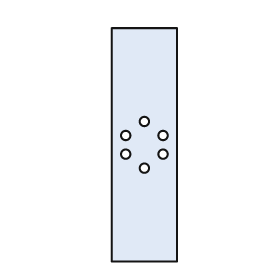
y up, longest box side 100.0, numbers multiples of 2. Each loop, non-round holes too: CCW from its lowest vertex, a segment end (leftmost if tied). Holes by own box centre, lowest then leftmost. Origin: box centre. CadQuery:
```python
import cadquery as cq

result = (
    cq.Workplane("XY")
    .moveTo(-14.0, -50.0)
    .lineTo(14.0, -50.0)
    .lineTo(14.0, 50.0)
    .lineTo(-14.0, 50.0)
    .close()
    .moveTo(0.0, -10.0)
    .circle(2.0)
    .moveTo(-8.0, -4.0)
    .circle(2.0)
    .moveTo(8.0, -4.0)
    .circle(2.0)
    .moveTo(-8.0, 4.0)
    .circle(2.0)
    .moveTo(8.0, 4.0)
    .circle(2.0)
    .moveTo(0.0, 10.0)
    .circle(2.0)
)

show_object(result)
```